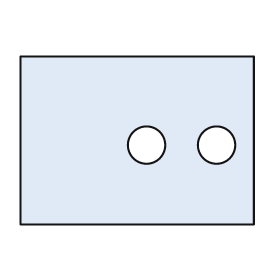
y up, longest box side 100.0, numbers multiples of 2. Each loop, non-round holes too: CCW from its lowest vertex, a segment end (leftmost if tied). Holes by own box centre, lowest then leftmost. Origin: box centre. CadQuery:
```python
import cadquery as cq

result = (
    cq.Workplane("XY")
    .moveTo(-50.0, -36.0)
    .lineTo(50.0, -36.0)
    .lineTo(50.0, 36.0)
    .lineTo(-50.0, 36.0)
    .close()
    .moveTo(4.0, -2.0)
    .circle(8.0)
    .moveTo(34.0, -2.0)
    .circle(8.0)
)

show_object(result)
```